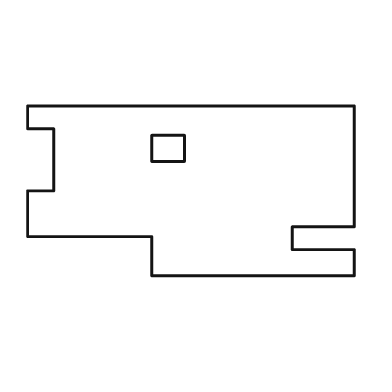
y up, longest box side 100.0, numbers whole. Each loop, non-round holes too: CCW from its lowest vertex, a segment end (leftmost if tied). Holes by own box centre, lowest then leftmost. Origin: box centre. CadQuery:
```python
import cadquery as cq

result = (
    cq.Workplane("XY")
    .moveTo(-12.0, -26.0)
    .lineTo(50.0, -26.0)
    .lineTo(50.0, -18.0)
    .lineTo(31.0, -18.0)
    .lineTo(31.0, -11.0)
    .lineTo(50.0, -11.0)
    .lineTo(50.0, 26.0)
    .lineTo(-50.0, 26.0)
    .lineTo(-50.0, 19.0)
    .lineTo(-42.0, 19.0)
    .lineTo(-42.0, 0.0)
    .lineTo(-50.0, 0.0)
    .lineTo(-50.0, -14.0)
    .lineTo(-12.0, -14.0)
    .close()
    .moveTo(-12.0, 9.0)
    .lineTo(-2.0, 9.0)
    .lineTo(-2.0, 17.0)
    .lineTo(-12.0, 17.0)
    .close()
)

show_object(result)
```